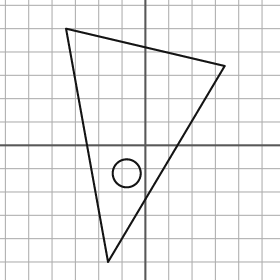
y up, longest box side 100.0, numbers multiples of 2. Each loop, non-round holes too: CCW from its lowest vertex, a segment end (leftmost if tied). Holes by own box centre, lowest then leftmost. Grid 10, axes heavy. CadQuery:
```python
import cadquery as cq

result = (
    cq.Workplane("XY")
    .moveTo(-16.0, -50.0)
    .lineTo(34.0, 34.0)
    .lineTo(-34.0, 50.0)
    .close()
    .moveTo(-8.0, -12.0)
    .circle(6.0)
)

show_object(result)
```